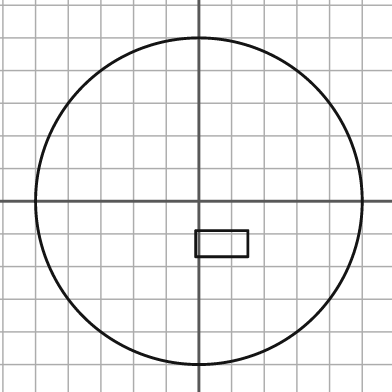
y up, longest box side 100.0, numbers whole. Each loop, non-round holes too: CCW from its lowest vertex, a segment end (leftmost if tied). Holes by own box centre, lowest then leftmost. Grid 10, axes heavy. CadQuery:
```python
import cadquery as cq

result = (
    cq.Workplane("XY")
    .moveTo(0.0, 0.0)
    .circle(50.0)
    .moveTo(-1.0, -17.0)
    .lineTo(15.0, -17.0)
    .lineTo(15.0, -9.0)
    .lineTo(-1.0, -9.0)
    .close()
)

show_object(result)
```